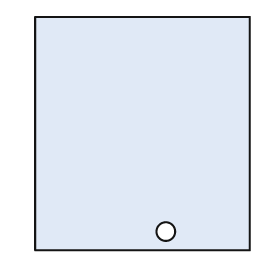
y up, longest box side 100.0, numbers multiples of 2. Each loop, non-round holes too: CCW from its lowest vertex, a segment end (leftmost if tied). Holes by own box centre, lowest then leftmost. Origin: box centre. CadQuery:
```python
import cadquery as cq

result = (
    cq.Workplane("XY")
    .moveTo(-46.0, -50.0)
    .lineTo(46.0, -50.0)
    .lineTo(46.0, 50.0)
    .lineTo(-46.0, 50.0)
    .close()
    .moveTo(10.0, -42.0)
    .circle(4.0)
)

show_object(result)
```